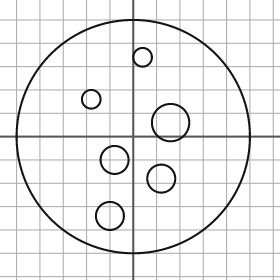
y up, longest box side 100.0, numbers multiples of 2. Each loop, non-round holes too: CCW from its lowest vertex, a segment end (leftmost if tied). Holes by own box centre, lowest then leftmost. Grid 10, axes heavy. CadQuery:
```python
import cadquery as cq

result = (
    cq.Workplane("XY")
    .moveTo(0.0, 0.0)
    .circle(50.0)
    .moveTo(-10.0, -34.0)
    .circle(6.0)
    .moveTo(12.0, -18.0)
    .circle(6.0)
    .moveTo(-8.0, -10.0)
    .circle(6.0)
    .moveTo(16.0, 6.0)
    .circle(8.0)
    .moveTo(-18.0, 16.0)
    .circle(4.0)
    .moveTo(4.0, 34.0)
    .circle(4.0)
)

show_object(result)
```